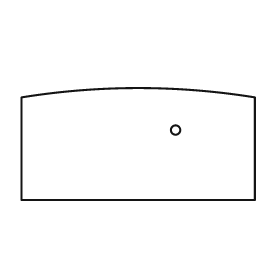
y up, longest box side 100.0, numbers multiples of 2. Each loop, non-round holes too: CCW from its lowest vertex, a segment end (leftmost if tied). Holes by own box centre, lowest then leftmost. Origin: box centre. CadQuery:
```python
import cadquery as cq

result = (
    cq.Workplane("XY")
    .moveTo(-50.0, -24.0)
    .lineTo(50.0, -24.0)
    .lineTo(50.0, 20.0)
    .threePointArc((0.0, 24.0), (-50.0, 20.0))
    .close()
    .moveTo(16.0, 6.0)
    .circle(2.0)
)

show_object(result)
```